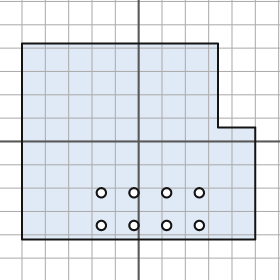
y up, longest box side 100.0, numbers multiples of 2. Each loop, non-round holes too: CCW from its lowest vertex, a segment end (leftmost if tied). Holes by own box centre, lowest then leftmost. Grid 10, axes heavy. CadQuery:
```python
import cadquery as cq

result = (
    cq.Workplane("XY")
    .moveTo(-50.0, -42.0)
    .lineTo(50.0, -42.0)
    .lineTo(50.0, 6.0)
    .lineTo(34.0, 6.0)
    .lineTo(34.0, 42.0)
    .lineTo(-50.0, 42.0)
    .close()
    .moveTo(-16.0, -36.0)
    .circle(2.0)
    .moveTo(-2.0, -36.0)
    .circle(2.0)
    .moveTo(12.0, -36.0)
    .circle(2.0)
    .moveTo(26.0, -36.0)
    .circle(2.0)
    .moveTo(-16.0, -22.0)
    .circle(2.0)
    .moveTo(-2.0, -22.0)
    .circle(2.0)
    .moveTo(12.0, -22.0)
    .circle(2.0)
    .moveTo(26.0, -22.0)
    .circle(2.0)
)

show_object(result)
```